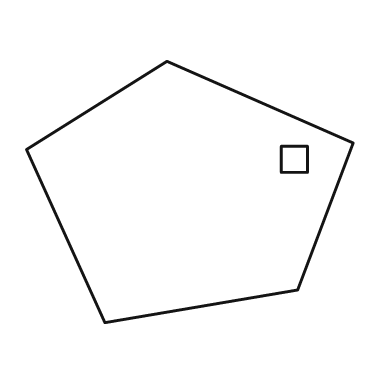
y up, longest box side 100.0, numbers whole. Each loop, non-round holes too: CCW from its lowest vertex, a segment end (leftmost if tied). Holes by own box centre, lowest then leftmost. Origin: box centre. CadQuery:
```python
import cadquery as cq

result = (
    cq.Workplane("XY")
    .moveTo(-26.0, -40.0)
    .lineTo(33.0, -30.0)
    .lineTo(50.0, 15.0)
    .lineTo(-7.0, 40.0)
    .lineTo(-50.0, 13.0)
    .close()
    .moveTo(28.0, 6.0)
    .lineTo(36.0, 6.0)
    .lineTo(36.0, 14.0)
    .lineTo(28.0, 14.0)
    .close()
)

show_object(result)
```